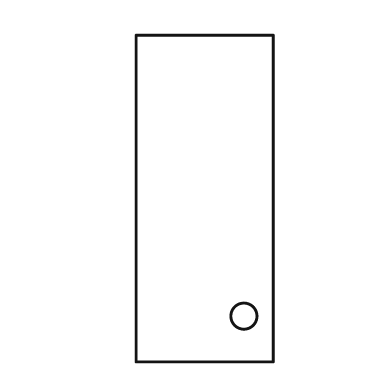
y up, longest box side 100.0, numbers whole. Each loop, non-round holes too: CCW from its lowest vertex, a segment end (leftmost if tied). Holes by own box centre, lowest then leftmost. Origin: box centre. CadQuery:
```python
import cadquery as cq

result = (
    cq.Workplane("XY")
    .moveTo(-21.0, -50.0)
    .lineTo(21.0, -50.0)
    .lineTo(21.0, 50.0)
    .lineTo(-21.0, 50.0)
    .close()
    .moveTo(12.0, -36.0)
    .circle(4.0)
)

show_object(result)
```